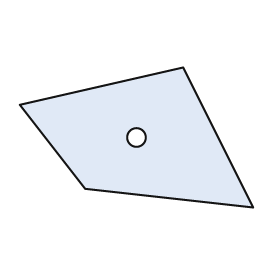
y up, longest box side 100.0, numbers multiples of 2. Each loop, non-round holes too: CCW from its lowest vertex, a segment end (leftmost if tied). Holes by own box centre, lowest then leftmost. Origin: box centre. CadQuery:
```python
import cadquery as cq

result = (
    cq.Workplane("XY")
    .moveTo(50.0, -30.0)
    .lineTo(20.0, 30.0)
    .lineTo(-50.0, 14.0)
    .lineTo(-22.0, -22.0)
    .close()
    .moveTo(0.0, 0.0)
    .circle(4.0)
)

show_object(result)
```